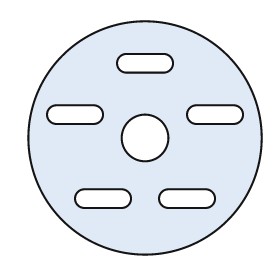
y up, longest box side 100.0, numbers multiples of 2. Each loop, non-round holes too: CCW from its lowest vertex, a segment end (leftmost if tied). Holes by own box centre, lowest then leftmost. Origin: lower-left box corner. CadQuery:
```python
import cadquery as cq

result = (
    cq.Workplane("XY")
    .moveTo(50.0, 50.0)
    .circle(50.0)
    .moveTo(24.0, 20.0)
    .lineTo(40.0, 20.0)
    .threePointArc((44.0, 24.0), (40.0, 28.0))
    .lineTo(24.0, 28.0)
    .threePointArc((20.0, 24.0), (24.0, 20.0))
    .close()
    .moveTo(60.0, 20.0)
    .lineTo(76.0, 20.0)
    .threePointArc((80.0, 24.0), (76.0, 28.0))
    .lineTo(60.0, 28.0)
    .threePointArc((56.0, 24.0), (60.0, 20.0))
    .close()
    .moveTo(50.0, 50.0)
    .circle(10.0)
    .moveTo(12.0, 56.0)
    .lineTo(28.0, 56.0)
    .threePointArc((32.0, 60.0), (28.0, 64.0))
    .lineTo(12.0, 64.0)
    .threePointArc((8.0, 60.0), (12.0, 56.0))
    .close()
    .moveTo(72.0, 56.0)
    .lineTo(88.0, 56.0)
    .threePointArc((92.0, 60.0), (88.0, 64.0))
    .lineTo(72.0, 64.0)
    .threePointArc((68.0, 60.0), (72.0, 56.0))
    .close()
    .moveTo(42.0, 78.0)
    .lineTo(58.0, 78.0)
    .threePointArc((62.0, 82.0), (58.0, 86.0))
    .lineTo(42.0, 86.0)
    .threePointArc((38.0, 82.0), (42.0, 78.0))
    .close()
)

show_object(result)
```